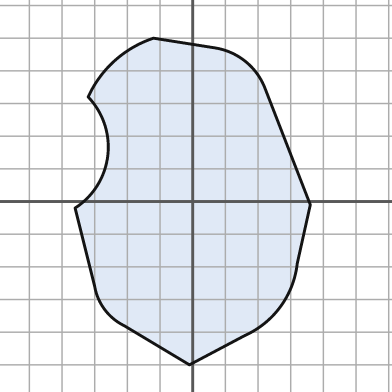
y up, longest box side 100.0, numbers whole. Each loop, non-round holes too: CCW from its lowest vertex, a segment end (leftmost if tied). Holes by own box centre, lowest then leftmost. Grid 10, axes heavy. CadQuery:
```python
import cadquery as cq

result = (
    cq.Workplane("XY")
    .moveTo(-1.0, -50.0)
    .lineTo(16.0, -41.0)
    .threePointArc((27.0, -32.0), (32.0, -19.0))
    .lineTo(36.0, -1.0)
    .lineTo(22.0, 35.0)
    .threePointArc((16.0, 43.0), (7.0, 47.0))
    .lineTo(-12.0, 50.0)
    .threePointArc((-24.0, 43.0), (-32.0, 32.0))
    .threePointArc((-26.0, 14.0), (-36.0, -2.0))
    .lineTo(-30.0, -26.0)
    .threePointArc((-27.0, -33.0), (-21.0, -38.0))
    .close()
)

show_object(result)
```